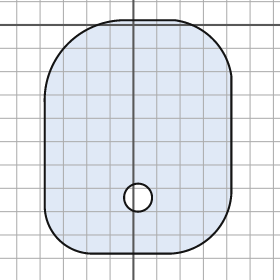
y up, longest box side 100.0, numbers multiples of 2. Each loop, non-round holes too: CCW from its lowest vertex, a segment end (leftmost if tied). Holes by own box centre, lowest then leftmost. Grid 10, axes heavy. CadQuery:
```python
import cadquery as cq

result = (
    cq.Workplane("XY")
    .moveTo(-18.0, -98.0)
    .lineTo(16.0, -98.0)
    .threePointArc((34.0, -90.0), (42.0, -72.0))
    .lineTo(42.0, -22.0)
    .threePointArc((34.0, -6.0), (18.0, 2.0))
    .lineTo(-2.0, 2.0)
    .threePointArc((-28.0, -8.0), (-38.0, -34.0))
    .lineTo(-38.0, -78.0)
    .threePointArc((-32.0, -92.0), (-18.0, -98.0))
    .close()
    .moveTo(2.0, -74.0)
    .circle(6.0)
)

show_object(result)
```